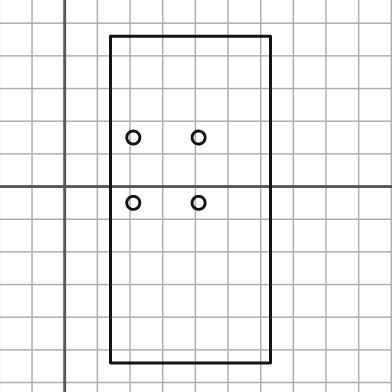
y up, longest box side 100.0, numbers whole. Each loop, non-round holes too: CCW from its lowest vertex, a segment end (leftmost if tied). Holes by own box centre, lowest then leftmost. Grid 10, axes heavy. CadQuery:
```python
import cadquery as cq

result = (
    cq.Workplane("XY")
    .moveTo(14.0, -54.0)
    .lineTo(63.0, -54.0)
    .lineTo(63.0, 46.0)
    .lineTo(14.0, 46.0)
    .close()
    .moveTo(21.0, -5.0)
    .circle(2.0)
    .moveTo(41.0, -5.0)
    .circle(2.0)
    .moveTo(21.0, 15.0)
    .circle(2.0)
    .moveTo(41.0, 15.0)
    .circle(2.0)
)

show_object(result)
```